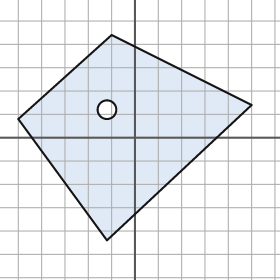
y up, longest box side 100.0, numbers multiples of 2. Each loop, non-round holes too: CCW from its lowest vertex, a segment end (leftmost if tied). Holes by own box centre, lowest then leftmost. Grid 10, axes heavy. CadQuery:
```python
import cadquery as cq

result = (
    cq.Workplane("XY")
    .moveTo(-12.0, -44.0)
    .lineTo(50.0, 14.0)
    .lineTo(-10.0, 44.0)
    .lineTo(-50.0, 8.0)
    .close()
    .moveTo(-12.0, 12.0)
    .circle(4.0)
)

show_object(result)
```